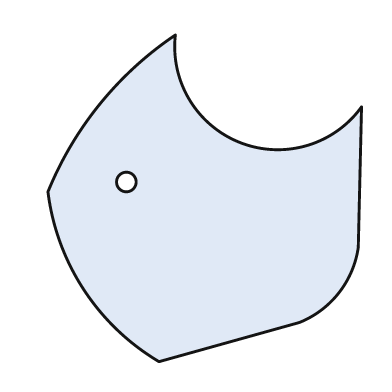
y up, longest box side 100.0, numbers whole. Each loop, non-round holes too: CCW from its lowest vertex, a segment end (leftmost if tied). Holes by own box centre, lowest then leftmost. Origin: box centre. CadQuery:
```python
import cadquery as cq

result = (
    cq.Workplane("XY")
    .moveTo(-14.0, -50.0)
    .lineTo(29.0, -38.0)
    .threePointArc((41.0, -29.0), (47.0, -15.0))
    .lineTo(48.0, 28.0)
    .threePointArc((11.0, 17.0), (-9.0, 50.0))
    .threePointArc((-32.0, 29.0), (-48.0, 2.0))
    .threePointArc((-37.0, -28.0), (-14.0, -50.0))
    .close()
    .moveTo(-24.0, 5.0)
    .circle(3.0)
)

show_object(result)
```